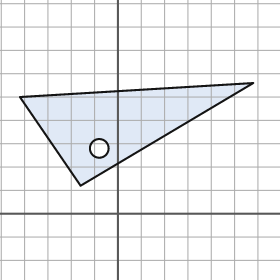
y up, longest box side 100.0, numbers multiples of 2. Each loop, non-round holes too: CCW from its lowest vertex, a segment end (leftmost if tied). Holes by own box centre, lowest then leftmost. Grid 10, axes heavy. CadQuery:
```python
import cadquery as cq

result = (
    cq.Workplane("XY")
    .moveTo(-16.0, 12.0)
    .lineTo(58.0, 56.0)
    .lineTo(-42.0, 50.0)
    .close()
    .moveTo(-8.0, 28.0)
    .circle(4.0)
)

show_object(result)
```